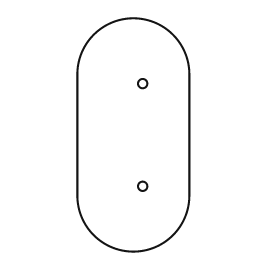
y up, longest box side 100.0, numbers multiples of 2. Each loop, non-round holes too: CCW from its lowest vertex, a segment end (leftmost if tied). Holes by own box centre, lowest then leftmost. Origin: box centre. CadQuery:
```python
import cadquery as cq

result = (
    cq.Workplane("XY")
    .moveTo(-24.0, -26.0)
    .threePointArc((0.0, -50.0), (24.0, -26.0))
    .lineTo(24.0, 26.0)
    .threePointArc((0.0, 50.0), (-24.0, 26.0))
    .close()
    .moveTo(4.0, -22.0)
    .circle(2.0)
    .moveTo(4.0, 22.0)
    .circle(2.0)
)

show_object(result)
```